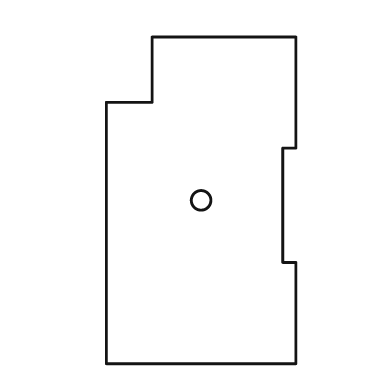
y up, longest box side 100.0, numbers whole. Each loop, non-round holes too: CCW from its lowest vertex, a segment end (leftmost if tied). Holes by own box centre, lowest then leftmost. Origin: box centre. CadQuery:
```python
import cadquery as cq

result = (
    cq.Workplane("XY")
    .moveTo(-29.0, -50.0)
    .lineTo(29.0, -50.0)
    .lineTo(29.0, -19.0)
    .lineTo(25.0, -19.0)
    .lineTo(25.0, 16.0)
    .lineTo(29.0, 16.0)
    .lineTo(29.0, 50.0)
    .lineTo(-15.0, 50.0)
    .lineTo(-15.0, 30.0)
    .lineTo(-29.0, 30.0)
    .close()
    .moveTo(0.0, 0.0)
    .circle(3.0)
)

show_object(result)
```